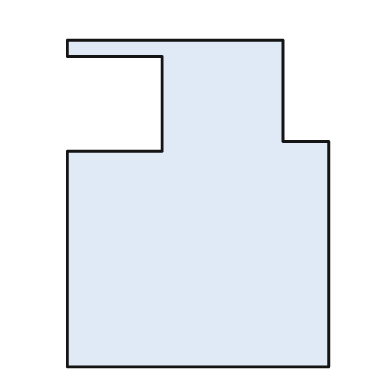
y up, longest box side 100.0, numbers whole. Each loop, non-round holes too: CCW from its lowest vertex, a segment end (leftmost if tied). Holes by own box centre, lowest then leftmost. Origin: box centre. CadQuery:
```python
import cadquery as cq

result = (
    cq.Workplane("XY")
    .moveTo(-40.0, -50.0)
    .lineTo(40.0, -50.0)
    .lineTo(40.0, 19.0)
    .lineTo(26.0, 19.0)
    .lineTo(26.0, 50.0)
    .lineTo(-40.0, 50.0)
    .lineTo(-40.0, 45.0)
    .lineTo(-11.0, 45.0)
    .lineTo(-11.0, 16.0)
    .lineTo(-40.0, 16.0)
    .close()
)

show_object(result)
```